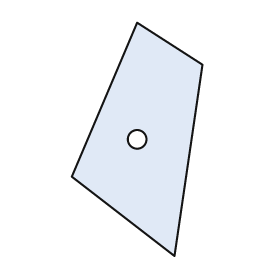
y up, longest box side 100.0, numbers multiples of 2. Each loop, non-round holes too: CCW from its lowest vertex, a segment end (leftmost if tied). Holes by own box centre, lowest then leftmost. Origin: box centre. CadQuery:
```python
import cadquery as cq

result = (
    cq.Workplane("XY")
    .moveTo(16.0, -50.0)
    .lineTo(28.0, 32.0)
    .lineTo(0.0, 50.0)
    .lineTo(-28.0, -16.0)
    .close()
    .moveTo(0.0, 0.0)
    .circle(4.0)
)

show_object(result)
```